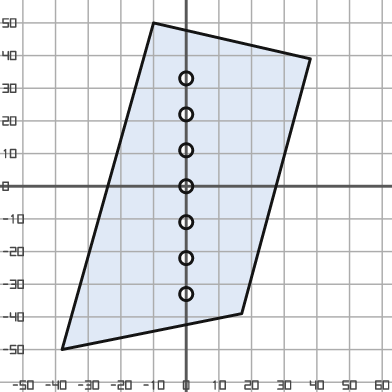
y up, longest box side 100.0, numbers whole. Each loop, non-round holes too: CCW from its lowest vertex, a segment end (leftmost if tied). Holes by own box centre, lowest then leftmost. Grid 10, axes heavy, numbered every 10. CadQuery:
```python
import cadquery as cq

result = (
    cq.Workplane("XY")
    .moveTo(-38.0, -50.0)
    .lineTo(17.0, -39.0)
    .lineTo(38.0, 39.0)
    .lineTo(-10.0, 50.0)
    .close()
    .moveTo(0.0, -33.0)
    .circle(2.0)
    .moveTo(0.0, -22.0)
    .circle(2.0)
    .moveTo(0.0, -11.0)
    .circle(2.0)
    .moveTo(0.0, 0.0)
    .circle(2.0)
    .moveTo(0.0, 11.0)
    .circle(2.0)
    .moveTo(0.0, 22.0)
    .circle(2.0)
    .moveTo(0.0, 33.0)
    .circle(2.0)
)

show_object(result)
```